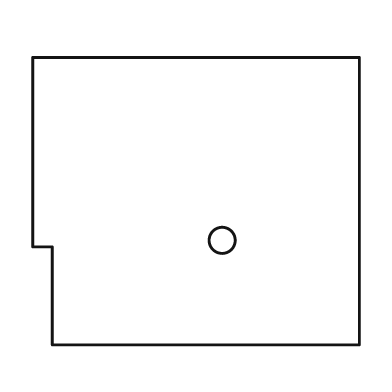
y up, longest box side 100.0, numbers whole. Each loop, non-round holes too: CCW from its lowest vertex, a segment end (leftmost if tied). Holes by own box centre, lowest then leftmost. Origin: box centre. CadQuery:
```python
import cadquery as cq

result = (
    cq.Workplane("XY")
    .moveTo(-44.0, -44.0)
    .lineTo(50.0, -44.0)
    .lineTo(50.0, 44.0)
    .lineTo(-50.0, 44.0)
    .lineTo(-50.0, -14.0)
    .lineTo(-44.0, -14.0)
    .close()
    .moveTo(8.0, -12.0)
    .circle(4.0)
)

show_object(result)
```